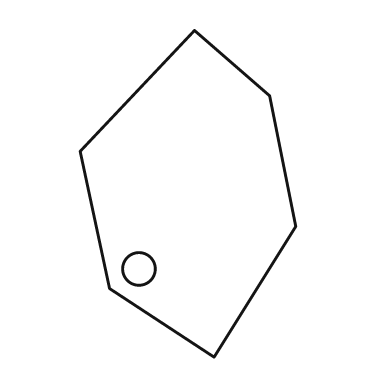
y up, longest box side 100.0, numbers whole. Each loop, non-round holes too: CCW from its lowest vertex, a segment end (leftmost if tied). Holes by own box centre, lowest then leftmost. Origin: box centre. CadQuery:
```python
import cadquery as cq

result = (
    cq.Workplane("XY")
    .moveTo(8.0, -50.0)
    .lineTo(33.0, -10.0)
    .lineTo(25.0, 30.0)
    .lineTo(2.0, 50.0)
    .lineTo(-33.0, 13.0)
    .lineTo(-24.0, -29.0)
    .close()
    .moveTo(-15.0, -23.0)
    .circle(5.0)
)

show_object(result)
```